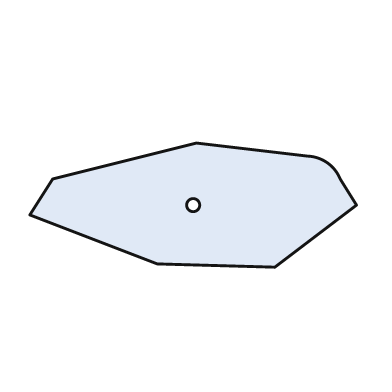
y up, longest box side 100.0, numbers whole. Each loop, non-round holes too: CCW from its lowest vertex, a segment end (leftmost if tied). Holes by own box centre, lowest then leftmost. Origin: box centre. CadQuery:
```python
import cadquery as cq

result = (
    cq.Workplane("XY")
    .moveTo(25.0, -19.0)
    .lineTo(50.0, 0.0)
    .lineTo(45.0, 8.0)
    .threePointArc((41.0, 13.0), (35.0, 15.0))
    .lineTo(1.0, 19.0)
    .lineTo(-43.0, 8.0)
    .lineTo(-50.0, -3.0)
    .lineTo(-11.0, -18.0)
    .close()
    .moveTo(0.0, 0.0)
    .circle(2.0)
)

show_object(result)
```